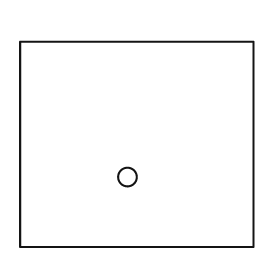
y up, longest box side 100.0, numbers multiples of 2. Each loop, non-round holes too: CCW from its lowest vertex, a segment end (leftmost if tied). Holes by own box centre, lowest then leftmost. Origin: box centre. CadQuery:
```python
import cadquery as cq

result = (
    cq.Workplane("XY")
    .moveTo(-50.0, -44.0)
    .lineTo(50.0, -44.0)
    .lineTo(50.0, 44.0)
    .lineTo(-50.0, 44.0)
    .close()
    .moveTo(-4.0, -14.0)
    .circle(4.0)
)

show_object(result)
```